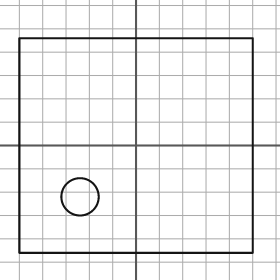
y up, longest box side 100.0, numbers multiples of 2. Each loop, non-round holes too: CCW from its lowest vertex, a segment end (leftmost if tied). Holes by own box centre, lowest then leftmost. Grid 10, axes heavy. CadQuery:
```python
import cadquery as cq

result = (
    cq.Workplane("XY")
    .moveTo(-50.0, -46.0)
    .lineTo(50.0, -46.0)
    .lineTo(50.0, 46.0)
    .lineTo(-50.0, 46.0)
    .close()
    .moveTo(-24.0, -22.0)
    .circle(8.0)
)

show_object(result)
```